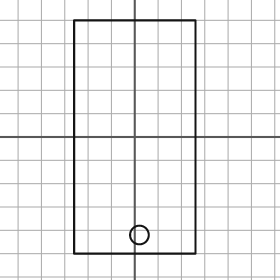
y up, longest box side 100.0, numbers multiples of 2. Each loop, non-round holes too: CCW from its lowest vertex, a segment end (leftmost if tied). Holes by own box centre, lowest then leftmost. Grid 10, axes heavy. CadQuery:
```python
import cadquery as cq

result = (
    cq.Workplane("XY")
    .moveTo(-26.0, -50.0)
    .lineTo(26.0, -50.0)
    .lineTo(26.0, 50.0)
    .lineTo(-26.0, 50.0)
    .close()
    .moveTo(2.0, -42.0)
    .circle(4.0)
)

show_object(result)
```